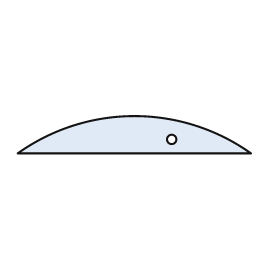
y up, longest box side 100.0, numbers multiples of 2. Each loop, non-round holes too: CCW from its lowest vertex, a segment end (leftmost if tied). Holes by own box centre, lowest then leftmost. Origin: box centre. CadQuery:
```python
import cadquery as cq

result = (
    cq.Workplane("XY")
    .moveTo(-50.0, -8.0)
    .lineTo(50.0, -8.0)
    .threePointArc((0.0, 8.0), (-50.0, -8.0))
    .close()
    .moveTo(16.0, -2.0)
    .circle(2.0)
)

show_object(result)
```